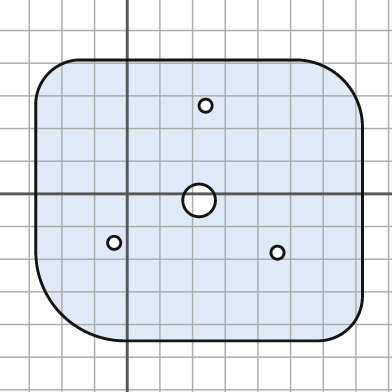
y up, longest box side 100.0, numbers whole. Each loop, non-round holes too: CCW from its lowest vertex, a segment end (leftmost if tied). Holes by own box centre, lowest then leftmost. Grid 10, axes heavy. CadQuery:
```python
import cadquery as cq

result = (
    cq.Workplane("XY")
    .moveTo(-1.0, -45.0)
    .lineTo(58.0, -45.0)
    .threePointArc((68.0, -41.0), (72.0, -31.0))
    .lineTo(72.0, 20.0)
    .threePointArc((66.0, 35.0), (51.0, 41.0))
    .lineTo(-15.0, 41.0)
    .threePointArc((-24.0, 37.0), (-28.0, 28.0))
    .lineTo(-28.0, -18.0)
    .threePointArc((-20.0, -37.0), (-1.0, -45.0))
    .close()
    .moveTo(46.0, -18.0)
    .circle(2.0)
    .moveTo(-4.0, -15.0)
    .circle(2.0)
    .moveTo(22.0, -2.0)
    .circle(5.0)
    .moveTo(24.0, 27.0)
    .circle(2.0)
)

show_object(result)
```